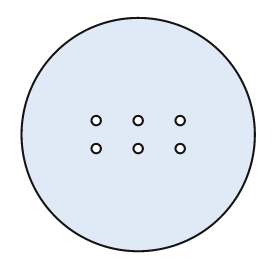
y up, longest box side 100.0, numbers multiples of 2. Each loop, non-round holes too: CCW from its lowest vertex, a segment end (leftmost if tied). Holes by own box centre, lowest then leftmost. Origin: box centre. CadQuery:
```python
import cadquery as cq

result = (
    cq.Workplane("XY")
    .moveTo(0.0, 0.0)
    .circle(50.0)
    .moveTo(-18.0, -6.0)
    .circle(2.0)
    .moveTo(0.0, -6.0)
    .circle(2.0)
    .moveTo(18.0, -6.0)
    .circle(2.0)
    .moveTo(-18.0, 6.0)
    .circle(2.0)
    .moveTo(0.0, 6.0)
    .circle(2.0)
    .moveTo(18.0, 6.0)
    .circle(2.0)
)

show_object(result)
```